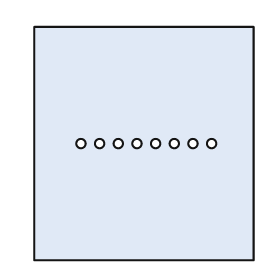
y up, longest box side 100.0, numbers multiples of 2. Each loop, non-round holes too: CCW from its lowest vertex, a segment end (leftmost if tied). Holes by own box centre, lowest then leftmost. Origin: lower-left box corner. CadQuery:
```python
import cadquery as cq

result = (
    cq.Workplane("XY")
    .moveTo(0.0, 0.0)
    .lineTo(94.0, 0.0)
    .lineTo(94.0, 100.0)
    .lineTo(0.0, 100.0)
    .close()
    .moveTo(20.0, 50.0)
    .circle(2.0)
    .moveTo(28.0, 50.0)
    .circle(2.0)
    .moveTo(36.0, 50.0)
    .circle(2.0)
    .moveTo(44.0, 50.0)
    .circle(2.0)
    .moveTo(52.0, 50.0)
    .circle(2.0)
    .moveTo(60.0, 50.0)
    .circle(2.0)
    .moveTo(68.0, 50.0)
    .circle(2.0)
    .moveTo(76.0, 50.0)
    .circle(2.0)
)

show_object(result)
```